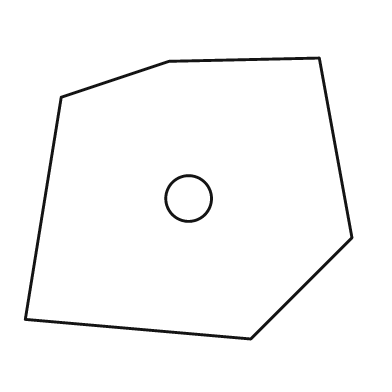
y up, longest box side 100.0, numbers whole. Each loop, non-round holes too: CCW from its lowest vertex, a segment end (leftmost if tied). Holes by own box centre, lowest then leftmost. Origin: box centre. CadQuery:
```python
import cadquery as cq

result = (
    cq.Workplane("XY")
    .moveTo(19.0, -43.0)
    .lineTo(50.0, -12.0)
    .lineTo(40.0, 43.0)
    .lineTo(-6.0, 42.0)
    .lineTo(-39.0, 31.0)
    .lineTo(-50.0, -37.0)
    .close()
    .moveTo(0.0, 0.0)
    .circle(7.0)
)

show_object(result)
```